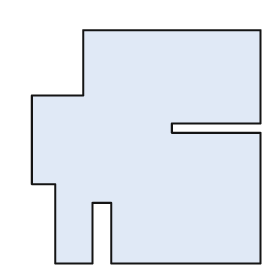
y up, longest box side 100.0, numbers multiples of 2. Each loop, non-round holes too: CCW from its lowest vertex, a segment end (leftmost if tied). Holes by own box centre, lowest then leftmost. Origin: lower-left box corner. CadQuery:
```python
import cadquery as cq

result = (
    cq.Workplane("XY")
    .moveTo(10.0, 0.0)
    .lineTo(26.0, 0.0)
    .lineTo(26.0, 26.0)
    .lineTo(34.0, 26.0)
    .lineTo(34.0, 0.0)
    .lineTo(98.0, 0.0)
    .lineTo(98.0, 56.0)
    .lineTo(60.0, 56.0)
    .lineTo(60.0, 60.0)
    .lineTo(98.0, 60.0)
    .lineTo(98.0, 100.0)
    .lineTo(22.0, 100.0)
    .lineTo(22.0, 72.0)
    .lineTo(0.0, 72.0)
    .lineTo(0.0, 34.0)
    .lineTo(10.0, 34.0)
    .close()
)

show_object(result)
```